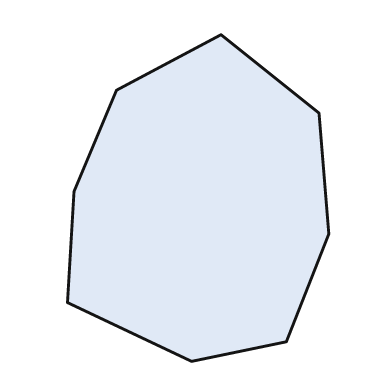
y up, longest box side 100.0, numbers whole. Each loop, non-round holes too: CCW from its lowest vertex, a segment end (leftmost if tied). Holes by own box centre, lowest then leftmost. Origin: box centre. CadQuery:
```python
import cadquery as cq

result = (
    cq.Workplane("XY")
    .moveTo(-2.0, -50.0)
    .lineTo(27.0, -44.0)
    .lineTo(40.0, -11.0)
    .lineTo(37.0, 26.0)
    .lineTo(7.0, 50.0)
    .lineTo(-25.0, 33.0)
    .lineTo(-38.0, 2.0)
    .lineTo(-40.0, -32.0)
    .close()
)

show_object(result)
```